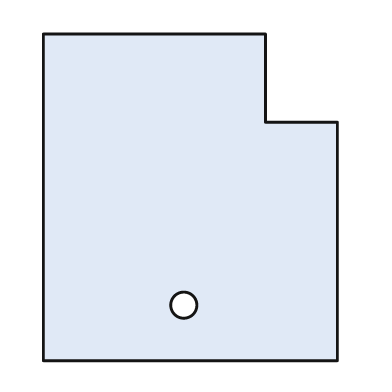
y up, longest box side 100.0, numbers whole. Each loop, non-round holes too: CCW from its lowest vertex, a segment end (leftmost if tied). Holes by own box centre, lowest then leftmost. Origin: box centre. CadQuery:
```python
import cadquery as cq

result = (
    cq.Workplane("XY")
    .moveTo(-45.0, -50.0)
    .lineTo(45.0, -50.0)
    .lineTo(45.0, 23.0)
    .lineTo(23.0, 23.0)
    .lineTo(23.0, 50.0)
    .lineTo(-45.0, 50.0)
    .close()
    .moveTo(-2.0, -33.0)
    .circle(4.0)
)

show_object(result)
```